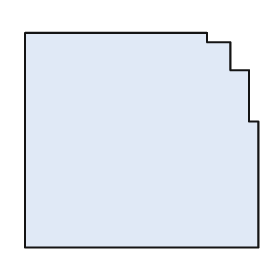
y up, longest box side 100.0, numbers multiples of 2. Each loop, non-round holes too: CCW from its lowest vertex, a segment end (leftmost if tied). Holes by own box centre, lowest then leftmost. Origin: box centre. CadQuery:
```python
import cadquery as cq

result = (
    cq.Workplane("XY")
    .moveTo(-50.0, -46.0)
    .lineTo(50.0, -46.0)
    .lineTo(50.0, 8.0)
    .lineTo(46.0, 8.0)
    .lineTo(46.0, 30.0)
    .lineTo(38.0, 30.0)
    .lineTo(38.0, 42.0)
    .lineTo(28.0, 42.0)
    .lineTo(28.0, 46.0)
    .lineTo(-50.0, 46.0)
    .close()
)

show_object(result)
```